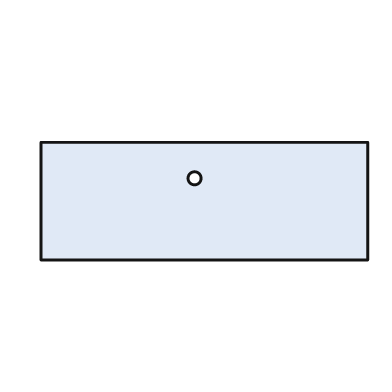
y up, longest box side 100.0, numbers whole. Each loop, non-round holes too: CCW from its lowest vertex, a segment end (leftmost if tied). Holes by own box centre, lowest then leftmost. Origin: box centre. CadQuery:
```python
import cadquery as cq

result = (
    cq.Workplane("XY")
    .moveTo(-50.0, -18.0)
    .lineTo(50.0, -18.0)
    .lineTo(50.0, 18.0)
    .lineTo(-50.0, 18.0)
    .close()
    .moveTo(-3.0, 7.0)
    .circle(2.0)
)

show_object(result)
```